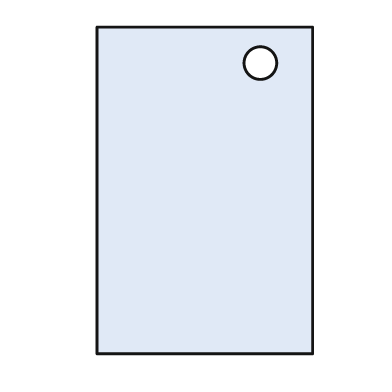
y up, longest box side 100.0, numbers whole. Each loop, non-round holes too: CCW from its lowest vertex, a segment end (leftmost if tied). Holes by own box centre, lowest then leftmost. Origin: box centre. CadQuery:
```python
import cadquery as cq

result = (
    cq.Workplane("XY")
    .moveTo(-33.0, -50.0)
    .lineTo(33.0, -50.0)
    .lineTo(33.0, 50.0)
    .lineTo(-33.0, 50.0)
    .close()
    .moveTo(17.0, 39.0)
    .circle(5.0)
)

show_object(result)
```